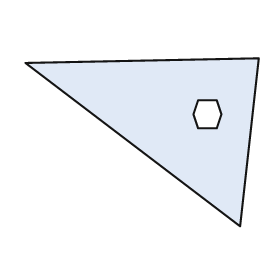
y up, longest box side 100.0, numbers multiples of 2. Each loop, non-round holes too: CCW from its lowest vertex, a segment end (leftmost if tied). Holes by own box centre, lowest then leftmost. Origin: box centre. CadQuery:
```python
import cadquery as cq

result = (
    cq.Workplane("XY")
    .moveTo(42.0, -36.0)
    .lineTo(50.0, 36.0)
    .lineTo(-50.0, 34.0)
    .close()
    .moveTo(24.0, 6.0)
    .lineTo(32.0, 6.0)
    .lineTo(34.0, 12.0)
    .lineTo(32.0, 18.0)
    .lineTo(24.0, 18.0)
    .lineTo(22.0, 12.0)
    .close()
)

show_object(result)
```